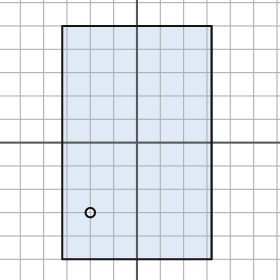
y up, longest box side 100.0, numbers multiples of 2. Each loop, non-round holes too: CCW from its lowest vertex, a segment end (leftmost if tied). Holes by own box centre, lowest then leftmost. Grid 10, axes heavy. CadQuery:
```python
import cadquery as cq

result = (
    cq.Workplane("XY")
    .moveTo(-32.0, -50.0)
    .lineTo(32.0, -50.0)
    .lineTo(32.0, 50.0)
    .lineTo(-32.0, 50.0)
    .close()
    .moveTo(-20.0, -30.0)
    .circle(2.0)
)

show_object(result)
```